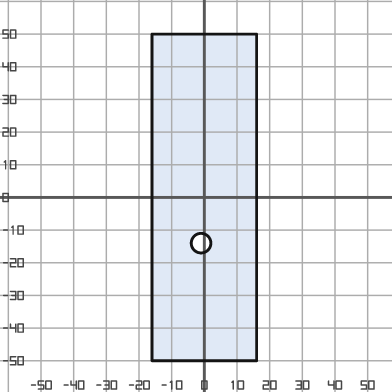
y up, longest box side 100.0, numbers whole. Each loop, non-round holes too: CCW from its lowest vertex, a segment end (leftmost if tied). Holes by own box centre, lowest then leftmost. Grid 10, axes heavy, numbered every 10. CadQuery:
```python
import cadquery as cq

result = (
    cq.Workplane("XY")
    .moveTo(-16.0, -50.0)
    .lineTo(16.0, -50.0)
    .lineTo(16.0, 50.0)
    .lineTo(-16.0, 50.0)
    .close()
    .moveTo(-1.0, -14.0)
    .circle(3.0)
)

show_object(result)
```